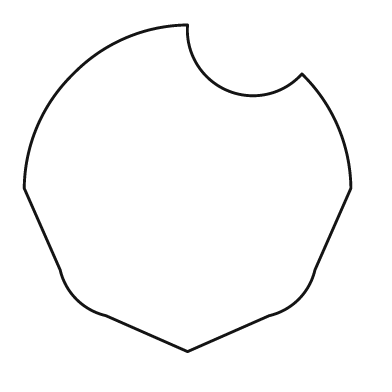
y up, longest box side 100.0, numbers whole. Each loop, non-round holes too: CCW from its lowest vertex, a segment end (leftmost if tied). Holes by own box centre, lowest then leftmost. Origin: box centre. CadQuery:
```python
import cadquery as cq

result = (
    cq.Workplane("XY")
    .moveTo(0.0, -50.0)
    .lineTo(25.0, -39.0)
    .threePointArc((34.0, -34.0), (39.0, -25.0))
    .lineTo(50.0, 0.0)
    .threePointArc((46.0, 19.0), (35.0, 35.0))
    .threePointArc((12.0, 30.0), (0.0, 50.0))
    .threePointArc((-19.0, 46.0), (-35.0, 35.0))
    .threePointArc((-46.0, 19.0), (-50.0, 0.0))
    .lineTo(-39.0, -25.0)
    .threePointArc((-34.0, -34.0), (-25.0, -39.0))
    .close()
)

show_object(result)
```